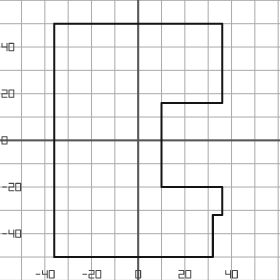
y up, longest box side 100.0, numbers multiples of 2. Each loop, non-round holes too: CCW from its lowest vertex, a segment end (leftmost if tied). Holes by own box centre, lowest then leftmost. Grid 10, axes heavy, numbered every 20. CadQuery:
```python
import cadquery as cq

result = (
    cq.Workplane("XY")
    .moveTo(-36.0, -50.0)
    .lineTo(32.0, -50.0)
    .lineTo(32.0, -32.0)
    .lineTo(36.0, -32.0)
    .lineTo(36.0, -20.0)
    .lineTo(10.0, -20.0)
    .lineTo(10.0, 16.0)
    .lineTo(36.0, 16.0)
    .lineTo(36.0, 50.0)
    .lineTo(-36.0, 50.0)
    .close()
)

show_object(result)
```